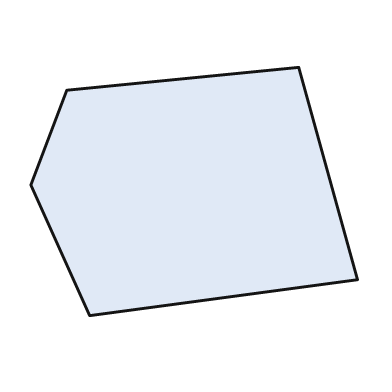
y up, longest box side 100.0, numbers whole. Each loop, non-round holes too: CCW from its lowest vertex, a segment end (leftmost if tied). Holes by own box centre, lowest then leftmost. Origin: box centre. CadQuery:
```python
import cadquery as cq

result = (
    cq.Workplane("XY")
    .moveTo(-32.0, -38.0)
    .lineTo(50.0, -27.0)
    .lineTo(32.0, 38.0)
    .lineTo(-39.0, 31.0)
    .lineTo(-50.0, 2.0)
    .close()
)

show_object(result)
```